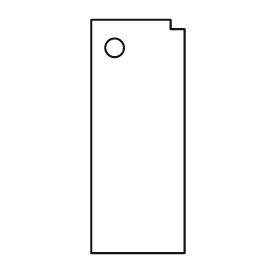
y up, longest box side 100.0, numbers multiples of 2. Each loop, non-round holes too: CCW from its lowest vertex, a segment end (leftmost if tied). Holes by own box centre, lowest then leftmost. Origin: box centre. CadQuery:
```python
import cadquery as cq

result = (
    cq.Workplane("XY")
    .moveTo(-20.0, -50.0)
    .lineTo(20.0, -50.0)
    .lineTo(20.0, 46.0)
    .lineTo(14.0, 46.0)
    .lineTo(14.0, 50.0)
    .lineTo(-20.0, 50.0)
    .close()
    .moveTo(-10.0, 38.0)
    .circle(4.0)
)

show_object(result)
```